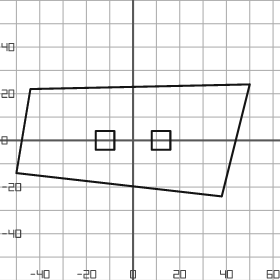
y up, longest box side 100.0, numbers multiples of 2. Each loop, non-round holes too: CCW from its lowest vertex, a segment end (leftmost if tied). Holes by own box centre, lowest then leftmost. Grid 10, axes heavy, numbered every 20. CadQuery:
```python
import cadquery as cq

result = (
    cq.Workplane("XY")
    .moveTo(38.0, -24.0)
    .lineTo(50.0, 24.0)
    .lineTo(-44.0, 22.0)
    .lineTo(-50.0, -14.0)
    .close()
    .moveTo(-16.0, -4.0)
    .lineTo(-8.0, -4.0)
    .lineTo(-8.0, 4.0)
    .lineTo(-16.0, 4.0)
    .close()
    .moveTo(8.0, -4.0)
    .lineTo(16.0, -4.0)
    .lineTo(16.0, 4.0)
    .lineTo(8.0, 4.0)
    .close()
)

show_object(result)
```